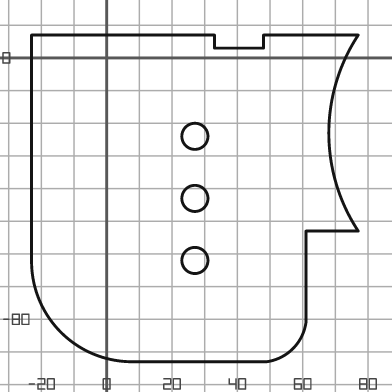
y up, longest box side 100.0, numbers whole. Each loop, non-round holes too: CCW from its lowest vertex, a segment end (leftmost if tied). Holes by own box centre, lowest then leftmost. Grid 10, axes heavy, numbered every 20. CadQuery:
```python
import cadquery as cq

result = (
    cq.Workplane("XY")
    .moveTo(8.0, -93.0)
    .lineTo(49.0, -93.0)
    .threePointArc((57.0, -89.0), (61.0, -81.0))
    .lineTo(61.0, -53.0)
    .lineTo(77.0, -53.0)
    .threePointArc((68.0, -23.0), (77.0, 7.0))
    .lineTo(48.0, 7.0)
    .lineTo(48.0, 3.0)
    .lineTo(33.0, 3.0)
    .lineTo(33.0, 7.0)
    .lineTo(-23.0, 7.0)
    .lineTo(-23.0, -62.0)
    .threePointArc((-14.0, -84.0), (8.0, -93.0))
    .close()
    .moveTo(27.0, -62.0)
    .circle(4.0)
    .moveTo(27.0, -43.0)
    .circle(4.0)
    .moveTo(27.0, -24.0)
    .circle(4.0)
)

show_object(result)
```